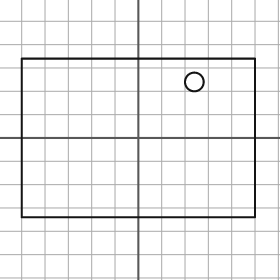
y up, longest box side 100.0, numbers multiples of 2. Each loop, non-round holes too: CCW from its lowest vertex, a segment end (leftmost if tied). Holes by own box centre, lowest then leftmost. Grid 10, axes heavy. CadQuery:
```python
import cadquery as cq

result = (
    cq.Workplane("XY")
    .moveTo(-50.0, -34.0)
    .lineTo(50.0, -34.0)
    .lineTo(50.0, 34.0)
    .lineTo(-50.0, 34.0)
    .close()
    .moveTo(24.0, 24.0)
    .circle(4.0)
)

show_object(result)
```